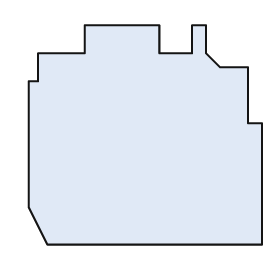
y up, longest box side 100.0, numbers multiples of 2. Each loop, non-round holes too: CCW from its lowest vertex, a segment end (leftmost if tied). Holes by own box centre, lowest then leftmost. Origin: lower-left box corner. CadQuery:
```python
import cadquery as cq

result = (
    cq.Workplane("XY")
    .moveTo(8.0, 0.0)
    .lineTo(100.0, 0.0)
    .lineTo(100.0, 52.0)
    .lineTo(94.0, 52.0)
    .lineTo(94.0, 76.0)
    .lineTo(82.0, 76.0)
    .lineTo(76.0, 82.0)
    .lineTo(76.0, 94.0)
    .lineTo(70.0, 94.0)
    .lineTo(70.0, 82.0)
    .lineTo(56.0, 82.0)
    .lineTo(56.0, 94.0)
    .lineTo(24.0, 94.0)
    .lineTo(24.0, 82.0)
    .lineTo(4.0, 82.0)
    .lineTo(4.0, 70.0)
    .lineTo(0.0, 70.0)
    .lineTo(0.0, 16.0)
    .close()
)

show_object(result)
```